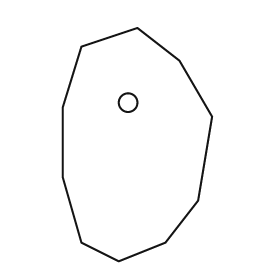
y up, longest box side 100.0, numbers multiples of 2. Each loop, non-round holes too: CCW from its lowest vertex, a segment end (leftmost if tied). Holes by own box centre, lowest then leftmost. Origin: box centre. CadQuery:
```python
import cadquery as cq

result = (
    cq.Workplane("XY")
    .moveTo(-8.0, -50.0)
    .lineTo(12.0, -42.0)
    .lineTo(26.0, -24.0)
    .lineTo(32.0, 12.0)
    .lineTo(18.0, 36.0)
    .lineTo(0.0, 50.0)
    .lineTo(-24.0, 42.0)
    .lineTo(-32.0, 16.0)
    .lineTo(-32.0, -14.0)
    .lineTo(-24.0, -42.0)
    .close()
    .moveTo(-4.0, 18.0)
    .circle(4.0)
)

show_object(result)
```